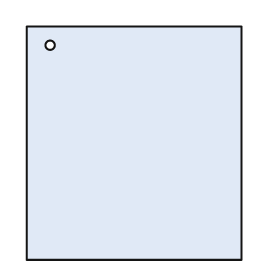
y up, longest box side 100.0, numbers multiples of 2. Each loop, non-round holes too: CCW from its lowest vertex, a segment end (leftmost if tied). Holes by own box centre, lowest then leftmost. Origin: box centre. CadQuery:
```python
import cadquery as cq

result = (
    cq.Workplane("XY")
    .moveTo(-46.0, -50.0)
    .lineTo(46.0, -50.0)
    .lineTo(46.0, 50.0)
    .lineTo(-46.0, 50.0)
    .close()
    .moveTo(-36.0, 42.0)
    .circle(2.0)
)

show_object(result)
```